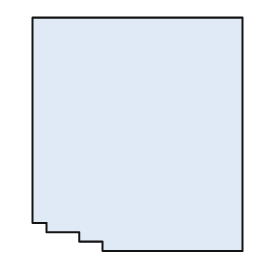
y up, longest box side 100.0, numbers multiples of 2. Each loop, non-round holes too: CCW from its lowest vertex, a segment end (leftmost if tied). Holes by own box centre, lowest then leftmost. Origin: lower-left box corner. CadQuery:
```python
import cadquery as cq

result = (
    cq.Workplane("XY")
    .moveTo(30.0, 0.0)
    .lineTo(90.0, 0.0)
    .lineTo(90.0, 100.0)
    .lineTo(0.0, 100.0)
    .lineTo(0.0, 12.0)
    .lineTo(6.0, 12.0)
    .lineTo(6.0, 8.0)
    .lineTo(20.0, 8.0)
    .lineTo(20.0, 4.0)
    .lineTo(30.0, 4.0)
    .close()
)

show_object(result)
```